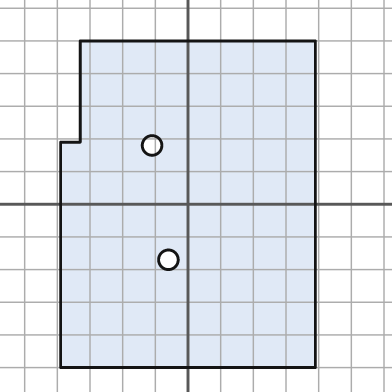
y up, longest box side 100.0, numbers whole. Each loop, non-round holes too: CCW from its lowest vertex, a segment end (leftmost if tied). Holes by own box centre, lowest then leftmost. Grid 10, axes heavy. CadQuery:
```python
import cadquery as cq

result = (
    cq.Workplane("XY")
    .moveTo(-39.0, -50.0)
    .lineTo(39.0, -50.0)
    .lineTo(39.0, 50.0)
    .lineTo(-33.0, 50.0)
    .lineTo(-33.0, 19.0)
    .lineTo(-39.0, 19.0)
    .close()
    .moveTo(-6.0, -17.0)
    .circle(3.0)
    .moveTo(-11.0, 18.0)
    .circle(3.0)
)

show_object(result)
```